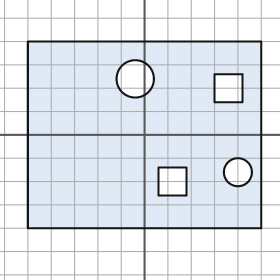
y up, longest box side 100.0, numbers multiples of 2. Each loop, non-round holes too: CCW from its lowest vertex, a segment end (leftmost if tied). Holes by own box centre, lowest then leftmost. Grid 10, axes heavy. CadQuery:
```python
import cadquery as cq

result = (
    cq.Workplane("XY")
    .moveTo(-50.0, -40.0)
    .lineTo(50.0, -40.0)
    .lineTo(50.0, 40.0)
    .lineTo(-50.0, 40.0)
    .close()
    .moveTo(6.0, -26.0)
    .lineTo(18.0, -26.0)
    .lineTo(18.0, -14.0)
    .lineTo(6.0, -14.0)
    .close()
    .moveTo(40.0, -16.0)
    .circle(6.0)
    .moveTo(30.0, 14.0)
    .lineTo(42.0, 14.0)
    .lineTo(42.0, 26.0)
    .lineTo(30.0, 26.0)
    .close()
    .moveTo(-4.0, 24.0)
    .circle(8.0)
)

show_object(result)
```